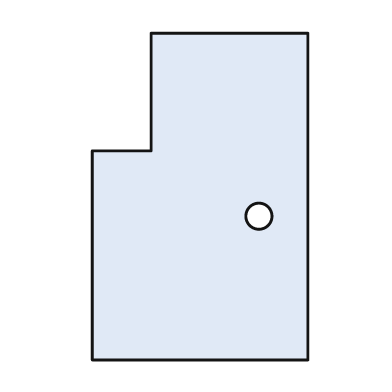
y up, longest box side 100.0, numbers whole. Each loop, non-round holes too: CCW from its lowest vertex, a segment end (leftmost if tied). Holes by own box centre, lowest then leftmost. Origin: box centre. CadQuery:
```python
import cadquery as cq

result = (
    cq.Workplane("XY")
    .moveTo(-33.0, -50.0)
    .lineTo(33.0, -50.0)
    .lineTo(33.0, 50.0)
    .lineTo(-15.0, 50.0)
    .lineTo(-15.0, 14.0)
    .lineTo(-33.0, 14.0)
    .close()
    .moveTo(18.0, -6.0)
    .circle(4.0)
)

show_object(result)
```